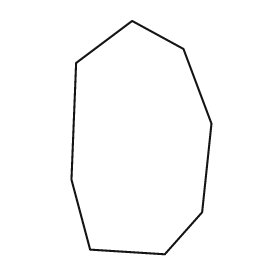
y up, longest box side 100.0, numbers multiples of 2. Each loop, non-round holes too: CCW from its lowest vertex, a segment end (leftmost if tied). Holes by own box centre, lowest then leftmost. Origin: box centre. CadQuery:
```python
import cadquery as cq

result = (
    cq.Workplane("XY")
    .moveTo(10.0, -50.0)
    .lineTo(26.0, -32.0)
    .lineTo(30.0, 6.0)
    .lineTo(18.0, 38.0)
    .lineTo(-4.0, 50.0)
    .lineTo(-28.0, 32.0)
    .lineTo(-30.0, -18.0)
    .lineTo(-22.0, -48.0)
    .close()
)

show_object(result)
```